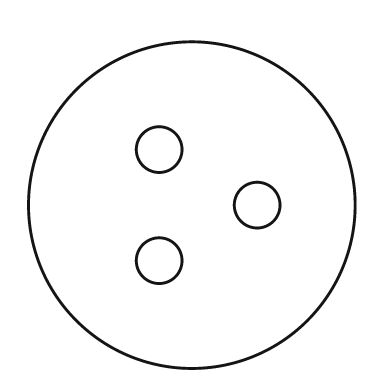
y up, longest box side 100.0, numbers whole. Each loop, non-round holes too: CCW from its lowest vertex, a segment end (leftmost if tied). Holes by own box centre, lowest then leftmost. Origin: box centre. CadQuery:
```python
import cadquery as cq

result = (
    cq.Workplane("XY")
    .moveTo(0.0, 0.0)
    .circle(50.0)
    .moveTo(-10.0, -17.0)
    .circle(7.0)
    .moveTo(20.0, 0.0)
    .circle(7.0)
    .moveTo(-10.0, 17.0)
    .circle(7.0)
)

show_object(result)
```